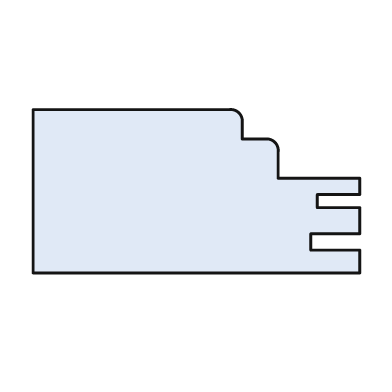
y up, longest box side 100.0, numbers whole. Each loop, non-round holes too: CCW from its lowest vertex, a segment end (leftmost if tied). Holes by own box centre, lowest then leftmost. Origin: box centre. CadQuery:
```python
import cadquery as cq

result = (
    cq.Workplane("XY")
    .moveTo(-50.0, -25.0)
    .lineTo(50.0, -25.0)
    .lineTo(50.0, -18.0)
    .lineTo(35.0, -18.0)
    .lineTo(35.0, -13.0)
    .lineTo(50.0, -13.0)
    .lineTo(50.0, -5.0)
    .lineTo(37.0, -5.0)
    .lineTo(37.0, -1.0)
    .lineTo(50.0, -1.0)
    .lineTo(50.0, 4.0)
    .lineTo(25.0, 4.0)
    .lineTo(25.0, 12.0)
    .threePointArc((24.0, 15.0), (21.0, 16.0))
    .lineTo(14.0, 16.0)
    .lineTo(14.0, 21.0)
    .threePointArc((13.0, 24.0), (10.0, 25.0))
    .lineTo(-50.0, 25.0)
    .close()
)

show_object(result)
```